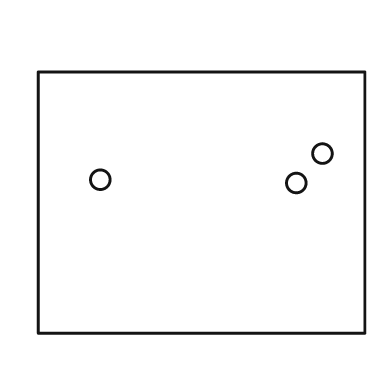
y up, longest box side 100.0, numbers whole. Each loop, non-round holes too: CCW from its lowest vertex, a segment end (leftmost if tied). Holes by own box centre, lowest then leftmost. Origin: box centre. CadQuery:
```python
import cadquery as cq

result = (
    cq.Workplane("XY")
    .moveTo(-50.0, -40.0)
    .lineTo(50.0, -40.0)
    .lineTo(50.0, 40.0)
    .lineTo(-50.0, 40.0)
    .close()
    .moveTo(29.0, 6.0)
    .circle(3.0)
    .moveTo(-31.0, 7.0)
    .circle(3.0)
    .moveTo(37.0, 15.0)
    .circle(3.0)
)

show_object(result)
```